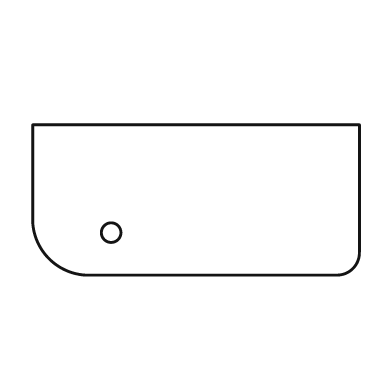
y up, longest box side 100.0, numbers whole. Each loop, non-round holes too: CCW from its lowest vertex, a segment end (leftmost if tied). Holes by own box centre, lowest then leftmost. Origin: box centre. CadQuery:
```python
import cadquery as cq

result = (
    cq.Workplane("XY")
    .moveTo(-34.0, -23.0)
    .lineTo(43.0, -23.0)
    .threePointArc((48.0, -21.0), (50.0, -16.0))
    .lineTo(50.0, 23.0)
    .lineTo(-50.0, 23.0)
    .lineTo(-50.0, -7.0)
    .threePointArc((-45.0, -18.0), (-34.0, -23.0))
    .close()
    .moveTo(-26.0, -10.0)
    .circle(3.0)
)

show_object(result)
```